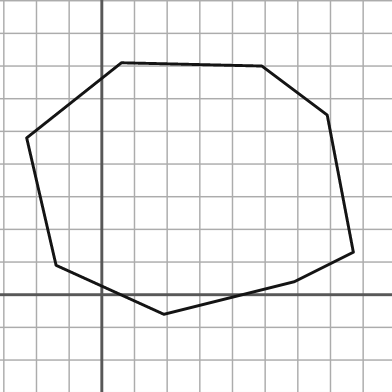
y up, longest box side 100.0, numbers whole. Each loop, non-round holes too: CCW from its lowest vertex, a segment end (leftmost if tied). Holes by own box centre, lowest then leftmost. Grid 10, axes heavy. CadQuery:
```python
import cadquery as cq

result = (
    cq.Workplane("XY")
    .moveTo(19.0, -6.0)
    .lineTo(59.0, 4.0)
    .lineTo(77.0, 13.0)
    .lineTo(69.0, 55.0)
    .lineTo(49.0, 70.0)
    .lineTo(6.0, 71.0)
    .lineTo(-23.0, 48.0)
    .lineTo(-14.0, 9.0)
    .close()
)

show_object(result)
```